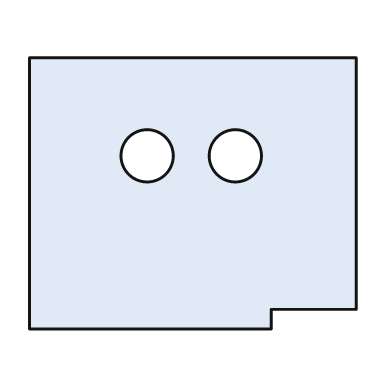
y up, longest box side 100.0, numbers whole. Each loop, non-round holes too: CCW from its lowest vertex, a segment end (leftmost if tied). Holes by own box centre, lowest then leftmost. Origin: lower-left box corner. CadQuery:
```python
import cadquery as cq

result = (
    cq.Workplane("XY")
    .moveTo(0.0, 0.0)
    .lineTo(74.0, 0.0)
    .lineTo(74.0, 6.0)
    .lineTo(100.0, 6.0)
    .lineTo(100.0, 83.0)
    .lineTo(0.0, 83.0)
    .close()
    .moveTo(36.0, 53.0)
    .circle(8.0)
    .moveTo(63.0, 53.0)
    .circle(8.0)
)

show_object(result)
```